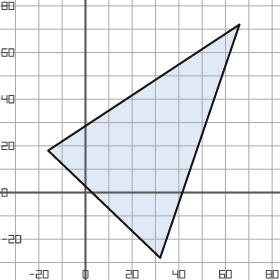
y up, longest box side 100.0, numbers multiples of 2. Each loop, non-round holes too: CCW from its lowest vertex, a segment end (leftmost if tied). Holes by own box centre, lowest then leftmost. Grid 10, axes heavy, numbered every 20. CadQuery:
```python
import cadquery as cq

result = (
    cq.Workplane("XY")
    .moveTo(32.0, -28.0)
    .lineTo(66.0, 72.0)
    .lineTo(-16.0, 18.0)
    .close()
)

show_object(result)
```